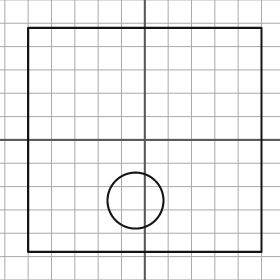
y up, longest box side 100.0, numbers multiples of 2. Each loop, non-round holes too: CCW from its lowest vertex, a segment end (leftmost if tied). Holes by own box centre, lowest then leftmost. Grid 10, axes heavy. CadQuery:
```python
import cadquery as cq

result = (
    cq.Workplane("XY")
    .moveTo(-50.0, -48.0)
    .lineTo(50.0, -48.0)
    .lineTo(50.0, 48.0)
    .lineTo(-50.0, 48.0)
    .close()
    .moveTo(-4.0, -26.0)
    .circle(12.0)
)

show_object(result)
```